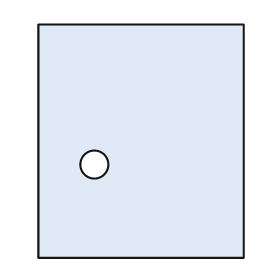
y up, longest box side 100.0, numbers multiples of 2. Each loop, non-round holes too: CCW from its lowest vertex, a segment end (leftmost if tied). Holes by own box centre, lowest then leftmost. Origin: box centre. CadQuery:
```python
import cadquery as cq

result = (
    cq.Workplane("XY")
    .moveTo(-44.0, -50.0)
    .lineTo(44.0, -50.0)
    .lineTo(44.0, 50.0)
    .lineTo(-44.0, 50.0)
    .close()
    .moveTo(-20.0, -10.0)
    .circle(6.0)
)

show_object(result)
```